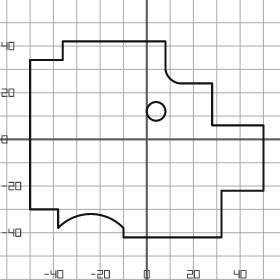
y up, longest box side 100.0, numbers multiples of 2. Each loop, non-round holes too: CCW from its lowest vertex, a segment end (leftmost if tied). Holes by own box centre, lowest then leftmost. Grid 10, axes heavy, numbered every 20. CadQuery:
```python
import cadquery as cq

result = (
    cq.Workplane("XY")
    .moveTo(-10.0, -42.0)
    .lineTo(32.0, -42.0)
    .lineTo(32.0, -22.0)
    .lineTo(50.0, -22.0)
    .lineTo(50.0, 6.0)
    .lineTo(28.0, 6.0)
    .lineTo(28.0, 24.0)
    .lineTo(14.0, 24.0)
    .threePointArc((10.0, 26.0), (8.0, 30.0))
    .lineTo(8.0, 42.0)
    .lineTo(-36.0, 42.0)
    .lineTo(-36.0, 34.0)
    .lineTo(-50.0, 34.0)
    .lineTo(-50.0, -30.0)
    .lineTo(-38.0, -30.0)
    .lineTo(-38.0, -38.0)
    .threePointArc((-24.0, -32.0), (-10.0, -38.0))
    .close()
    .moveTo(4.0, 12.0)
    .circle(4.0)
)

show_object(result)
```